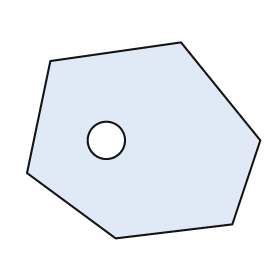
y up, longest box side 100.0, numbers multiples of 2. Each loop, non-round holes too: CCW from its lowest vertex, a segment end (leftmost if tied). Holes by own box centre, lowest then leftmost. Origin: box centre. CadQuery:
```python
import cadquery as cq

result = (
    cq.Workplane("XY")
    .moveTo(-12.0, -42.0)
    .lineTo(38.0, -36.0)
    .lineTo(50.0, 0.0)
    .lineTo(16.0, 42.0)
    .lineTo(-40.0, 34.0)
    .lineTo(-50.0, -14.0)
    .close()
    .moveTo(-16.0, 0.0)
    .circle(8.0)
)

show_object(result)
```